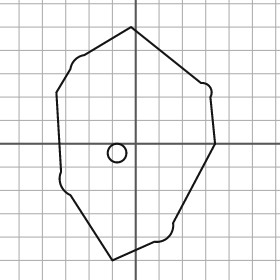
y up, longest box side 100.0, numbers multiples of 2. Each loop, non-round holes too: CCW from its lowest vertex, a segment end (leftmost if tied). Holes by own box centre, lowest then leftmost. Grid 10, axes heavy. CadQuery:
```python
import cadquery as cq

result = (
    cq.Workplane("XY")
    .moveTo(-10.0, -50.0)
    .lineTo(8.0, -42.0)
    .threePointArc((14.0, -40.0), (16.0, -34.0))
    .lineTo(34.0, 0.0)
    .lineTo(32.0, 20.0)
    .threePointArc((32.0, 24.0), (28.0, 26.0))
    .lineTo(-2.0, 50.0)
    .lineTo(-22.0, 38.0)
    .threePointArc((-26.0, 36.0), (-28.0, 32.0))
    .lineTo(-34.0, 22.0)
    .lineTo(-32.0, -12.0)
    .threePointArc((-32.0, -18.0), (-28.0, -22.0))
    .close()
    .moveTo(-8.0, -4.0)
    .circle(4.0)
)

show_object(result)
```